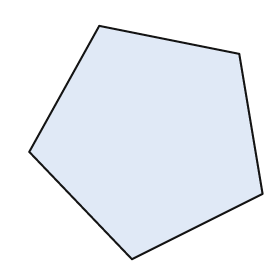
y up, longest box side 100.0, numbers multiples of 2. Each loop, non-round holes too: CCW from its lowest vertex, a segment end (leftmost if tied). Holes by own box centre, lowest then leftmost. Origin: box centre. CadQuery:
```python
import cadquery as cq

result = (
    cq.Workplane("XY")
    .moveTo(-6.0, -50.0)
    .lineTo(50.0, -22.0)
    .lineTo(40.0, 38.0)
    .lineTo(-20.0, 50.0)
    .lineTo(-50.0, -4.0)
    .close()
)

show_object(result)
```